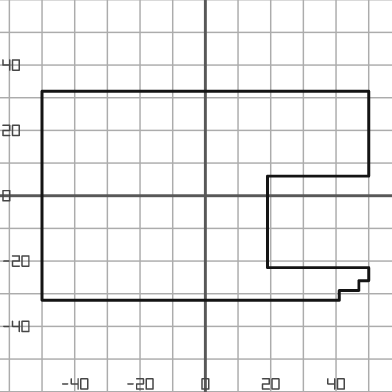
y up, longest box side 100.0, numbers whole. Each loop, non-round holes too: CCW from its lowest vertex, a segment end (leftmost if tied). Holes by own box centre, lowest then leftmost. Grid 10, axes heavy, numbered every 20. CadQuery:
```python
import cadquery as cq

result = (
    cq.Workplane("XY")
    .moveTo(-50.0, -32.0)
    .lineTo(41.0, -32.0)
    .lineTo(41.0, -29.0)
    .lineTo(47.0, -29.0)
    .lineTo(47.0, -26.0)
    .lineTo(50.0, -26.0)
    .lineTo(50.0, -22.0)
    .lineTo(19.0, -22.0)
    .lineTo(19.0, 6.0)
    .lineTo(50.0, 6.0)
    .lineTo(50.0, 32.0)
    .lineTo(-50.0, 32.0)
    .close()
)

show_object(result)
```